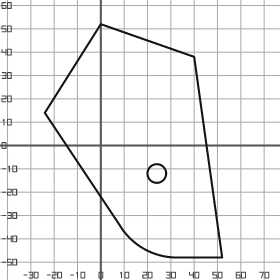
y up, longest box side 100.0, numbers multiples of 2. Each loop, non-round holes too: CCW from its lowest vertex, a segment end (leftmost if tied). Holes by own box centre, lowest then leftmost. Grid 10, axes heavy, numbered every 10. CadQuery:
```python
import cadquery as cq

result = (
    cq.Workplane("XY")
    .moveTo(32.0, -48.0)
    .lineTo(52.0, -48.0)
    .lineTo(40.0, 38.0)
    .lineTo(0.0, 52.0)
    .lineTo(-24.0, 14.0)
    .lineTo(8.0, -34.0)
    .threePointArc((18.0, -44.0), (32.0, -48.0))
    .close()
    .moveTo(24.0, -12.0)
    .circle(4.0)
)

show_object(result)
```